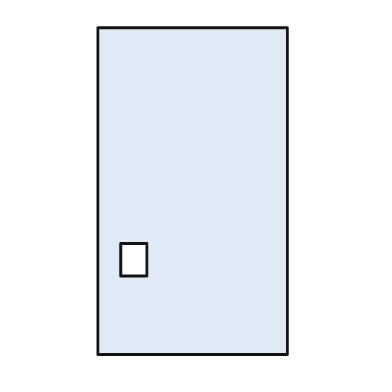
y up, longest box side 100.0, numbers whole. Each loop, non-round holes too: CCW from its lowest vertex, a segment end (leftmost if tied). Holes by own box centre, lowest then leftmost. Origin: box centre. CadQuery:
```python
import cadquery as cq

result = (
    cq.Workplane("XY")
    .moveTo(-29.0, -50.0)
    .lineTo(29.0, -50.0)
    .lineTo(29.0, 50.0)
    .lineTo(-29.0, 50.0)
    .close()
    .moveTo(-22.0, -26.0)
    .lineTo(-14.0, -26.0)
    .lineTo(-14.0, -16.0)
    .lineTo(-22.0, -16.0)
    .close()
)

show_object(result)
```